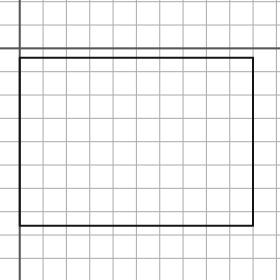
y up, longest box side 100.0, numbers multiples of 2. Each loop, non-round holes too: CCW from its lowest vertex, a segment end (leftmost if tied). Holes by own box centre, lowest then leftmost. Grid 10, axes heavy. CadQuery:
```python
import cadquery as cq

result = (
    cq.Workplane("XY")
    .moveTo(0.0, -76.0)
    .lineTo(100.0, -76.0)
    .lineTo(100.0, -4.0)
    .lineTo(0.0, -4.0)
    .close()
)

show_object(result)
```